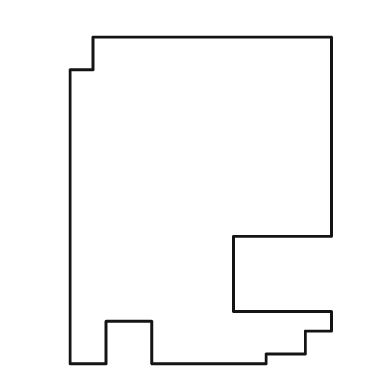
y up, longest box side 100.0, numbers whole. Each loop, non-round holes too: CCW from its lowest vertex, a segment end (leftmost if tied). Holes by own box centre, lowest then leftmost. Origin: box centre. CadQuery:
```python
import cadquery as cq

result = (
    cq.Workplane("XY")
    .moveTo(-40.0, -50.0)
    .lineTo(-29.0, -50.0)
    .lineTo(-29.0, -37.0)
    .lineTo(-15.0, -37.0)
    .lineTo(-15.0, -50.0)
    .lineTo(20.0, -50.0)
    .lineTo(20.0, -47.0)
    .lineTo(32.0, -47.0)
    .lineTo(32.0, -40.0)
    .lineTo(40.0, -40.0)
    .lineTo(40.0, -34.0)
    .lineTo(10.0, -34.0)
    .lineTo(10.0, -11.0)
    .lineTo(40.0, -11.0)
    .lineTo(40.0, 50.0)
    .lineTo(-33.0, 50.0)
    .lineTo(-33.0, 40.0)
    .lineTo(-40.0, 40.0)
    .close()
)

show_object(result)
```